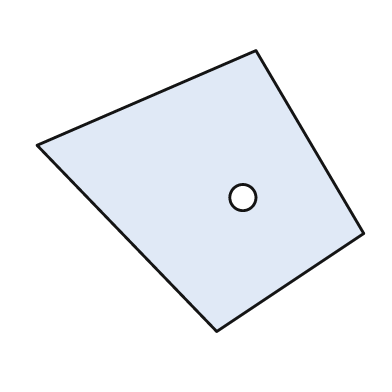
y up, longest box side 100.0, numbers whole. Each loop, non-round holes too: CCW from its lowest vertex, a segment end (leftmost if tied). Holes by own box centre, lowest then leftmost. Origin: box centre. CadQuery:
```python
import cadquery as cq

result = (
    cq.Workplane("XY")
    .moveTo(5.0, -43.0)
    .lineTo(50.0, -13.0)
    .lineTo(17.0, 43.0)
    .lineTo(-50.0, 14.0)
    .close()
    .moveTo(13.0, -2.0)
    .circle(4.0)
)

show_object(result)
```